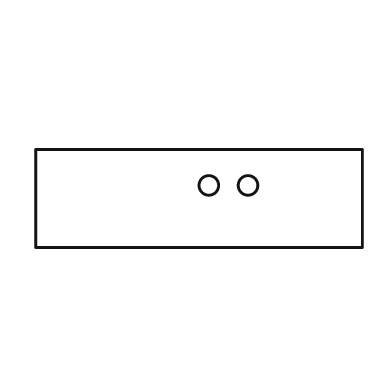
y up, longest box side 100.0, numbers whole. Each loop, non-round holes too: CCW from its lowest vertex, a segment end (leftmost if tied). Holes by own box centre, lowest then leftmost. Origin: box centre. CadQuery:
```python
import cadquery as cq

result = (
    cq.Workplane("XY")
    .moveTo(-50.0, -15.0)
    .lineTo(50.0, -15.0)
    .lineTo(50.0, 15.0)
    .lineTo(-50.0, 15.0)
    .close()
    .moveTo(3.0, 4.0)
    .circle(3.0)
    .moveTo(15.0, 4.0)
    .circle(3.0)
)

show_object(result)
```